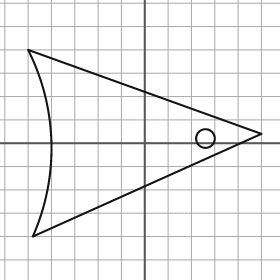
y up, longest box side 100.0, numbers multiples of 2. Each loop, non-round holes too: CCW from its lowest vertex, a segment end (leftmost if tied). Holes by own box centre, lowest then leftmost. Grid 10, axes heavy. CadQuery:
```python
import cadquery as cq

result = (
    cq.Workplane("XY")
    .moveTo(-48.0, -40.0)
    .lineTo(50.0, 4.0)
    .lineTo(-50.0, 40.0)
    .threePointArc((-40.0, 0.0), (-48.0, -40.0))
    .close()
    .moveTo(26.0, 2.0)
    .circle(4.0)
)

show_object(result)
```